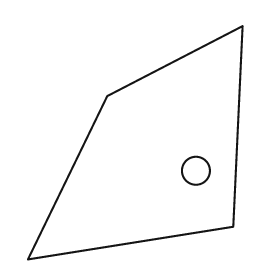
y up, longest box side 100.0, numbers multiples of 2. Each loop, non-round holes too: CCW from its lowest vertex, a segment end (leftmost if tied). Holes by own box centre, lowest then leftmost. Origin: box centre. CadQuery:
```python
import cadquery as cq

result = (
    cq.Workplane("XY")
    .moveTo(-46.0, -50.0)
    .lineTo(42.0, -36.0)
    .lineTo(46.0, 50.0)
    .lineTo(-12.0, 20.0)
    .close()
    .moveTo(26.0, -12.0)
    .circle(6.0)
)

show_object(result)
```